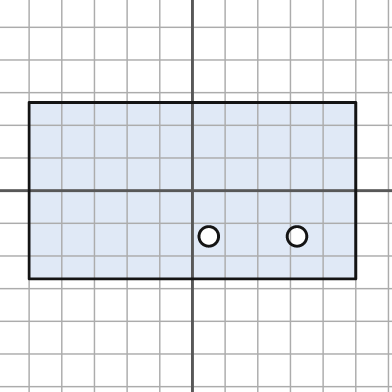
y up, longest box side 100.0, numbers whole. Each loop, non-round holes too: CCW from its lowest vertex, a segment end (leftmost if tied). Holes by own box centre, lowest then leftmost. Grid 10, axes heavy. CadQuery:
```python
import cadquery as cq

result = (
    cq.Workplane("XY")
    .moveTo(-50.0, -27.0)
    .lineTo(50.0, -27.0)
    .lineTo(50.0, 27.0)
    .lineTo(-50.0, 27.0)
    .close()
    .moveTo(5.0, -14.0)
    .circle(3.0)
    .moveTo(32.0, -14.0)
    .circle(3.0)
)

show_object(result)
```